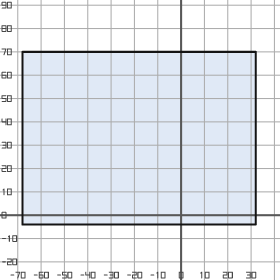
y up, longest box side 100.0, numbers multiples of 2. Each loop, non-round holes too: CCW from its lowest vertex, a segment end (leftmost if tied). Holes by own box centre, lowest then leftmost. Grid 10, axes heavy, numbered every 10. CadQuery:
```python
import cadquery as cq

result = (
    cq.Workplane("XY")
    .moveTo(-68.0, -4.0)
    .lineTo(32.0, -4.0)
    .lineTo(32.0, 70.0)
    .lineTo(-68.0, 70.0)
    .close()
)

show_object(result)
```